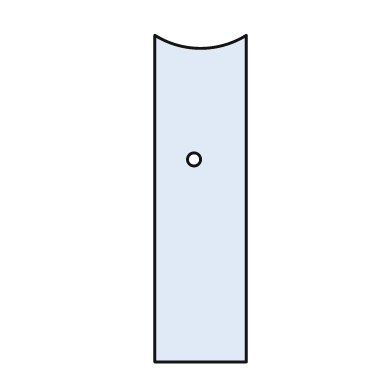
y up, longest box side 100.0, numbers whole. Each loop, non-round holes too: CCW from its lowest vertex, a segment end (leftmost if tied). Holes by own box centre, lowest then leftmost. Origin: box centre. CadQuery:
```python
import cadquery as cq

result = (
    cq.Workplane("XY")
    .moveTo(-14.0, -50.0)
    .lineTo(14.0, -50.0)
    .lineTo(14.0, 50.0)
    .threePointArc((0.0, 46.0), (-14.0, 50.0))
    .close()
    .moveTo(-2.0, 12.0)
    .circle(2.0)
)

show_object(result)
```